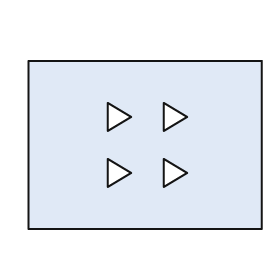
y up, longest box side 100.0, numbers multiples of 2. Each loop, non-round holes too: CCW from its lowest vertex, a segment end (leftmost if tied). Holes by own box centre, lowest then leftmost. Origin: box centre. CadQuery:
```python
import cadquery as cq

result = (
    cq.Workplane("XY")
    .moveTo(-50.0, -36.0)
    .lineTo(50.0, -36.0)
    .lineTo(50.0, 36.0)
    .lineTo(-50.0, 36.0)
    .close()
    .moveTo(-16.0, -18.0)
    .lineTo(-6.0, -12.0)
    .lineTo(-16.0, -6.0)
    .close()
    .moveTo(8.0, -18.0)
    .lineTo(18.0, -12.0)
    .lineTo(8.0, -6.0)
    .close()
    .moveTo(-16.0, 6.0)
    .lineTo(-6.0, 12.0)
    .lineTo(-16.0, 18.0)
    .close()
    .moveTo(8.0, 6.0)
    .lineTo(18.0, 12.0)
    .lineTo(8.0, 18.0)
    .close()
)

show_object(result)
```